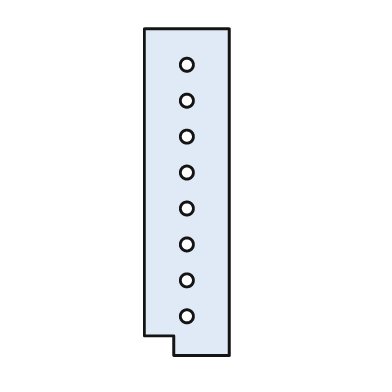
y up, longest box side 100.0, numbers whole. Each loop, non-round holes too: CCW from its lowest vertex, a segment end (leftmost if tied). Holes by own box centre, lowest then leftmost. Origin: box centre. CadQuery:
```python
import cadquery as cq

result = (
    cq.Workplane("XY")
    .moveTo(-4.0, -50.0)
    .lineTo(13.0, -50.0)
    .lineTo(13.0, 50.0)
    .lineTo(-13.0, 50.0)
    .lineTo(-13.0, -44.0)
    .lineTo(-4.0, -44.0)
    .close()
    .moveTo(0.0, -38.0)
    .circle(2.0)
    .moveTo(0.0, -27.0)
    .circle(2.0)
    .moveTo(0.0, -16.0)
    .circle(2.0)
    .moveTo(0.0, -5.0)
    .circle(2.0)
    .moveTo(0.0, 6.0)
    .circle(2.0)
    .moveTo(0.0, 17.0)
    .circle(2.0)
    .moveTo(0.0, 28.0)
    .circle(2.0)
    .moveTo(0.0, 39.0)
    .circle(2.0)
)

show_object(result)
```